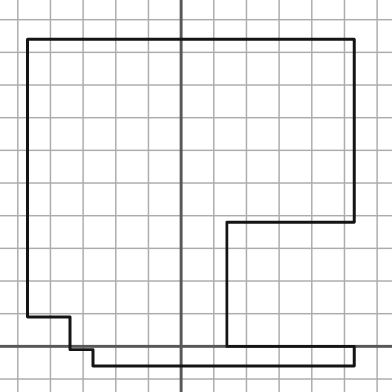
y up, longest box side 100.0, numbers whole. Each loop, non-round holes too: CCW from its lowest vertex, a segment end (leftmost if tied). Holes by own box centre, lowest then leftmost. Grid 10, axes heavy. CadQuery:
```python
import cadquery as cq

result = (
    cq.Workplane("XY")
    .moveTo(-27.0, -6.0)
    .lineTo(53.0, -6.0)
    .lineTo(53.0, 0.0)
    .lineTo(14.0, 0.0)
    .lineTo(14.0, 38.0)
    .lineTo(53.0, 38.0)
    .lineTo(53.0, 94.0)
    .lineTo(-47.0, 94.0)
    .lineTo(-47.0, 9.0)
    .lineTo(-34.0, 9.0)
    .lineTo(-34.0, -1.0)
    .lineTo(-27.0, -1.0)
    .close()
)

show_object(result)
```